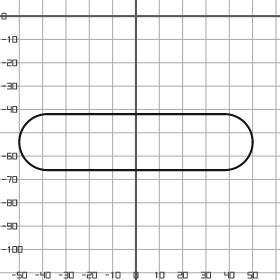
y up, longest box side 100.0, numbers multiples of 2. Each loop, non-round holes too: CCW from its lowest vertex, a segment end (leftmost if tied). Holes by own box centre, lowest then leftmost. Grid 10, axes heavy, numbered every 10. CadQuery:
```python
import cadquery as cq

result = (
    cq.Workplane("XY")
    .moveTo(-38.0, -66.0)
    .lineTo(38.0, -66.0)
    .threePointArc((50.0, -54.0), (38.0, -42.0))
    .lineTo(-38.0, -42.0)
    .threePointArc((-50.0, -54.0), (-38.0, -66.0))
    .close()
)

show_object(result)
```